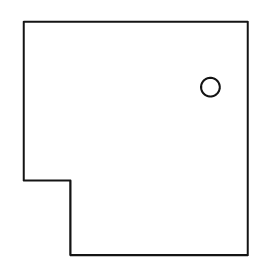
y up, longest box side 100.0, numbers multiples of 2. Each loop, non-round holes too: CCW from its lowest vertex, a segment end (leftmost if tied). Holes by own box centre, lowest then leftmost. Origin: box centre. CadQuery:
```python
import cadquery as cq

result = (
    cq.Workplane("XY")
    .moveTo(-28.0, -50.0)
    .lineTo(48.0, -50.0)
    .lineTo(48.0, 50.0)
    .lineTo(-48.0, 50.0)
    .lineTo(-48.0, -18.0)
    .lineTo(-28.0, -18.0)
    .close()
    .moveTo(32.0, 22.0)
    .circle(4.0)
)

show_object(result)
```